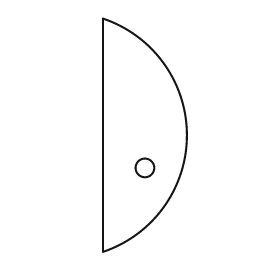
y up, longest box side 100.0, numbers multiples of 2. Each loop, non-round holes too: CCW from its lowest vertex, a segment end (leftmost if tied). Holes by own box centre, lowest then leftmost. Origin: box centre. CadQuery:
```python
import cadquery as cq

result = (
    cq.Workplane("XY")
    .moveTo(-18.0, -50.0)
    .threePointArc((18.0, 0.0), (-18.0, 50.0))
    .close()
    .moveTo(0.0, -14.0)
    .circle(4.0)
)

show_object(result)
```